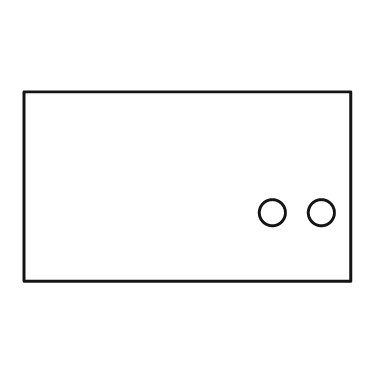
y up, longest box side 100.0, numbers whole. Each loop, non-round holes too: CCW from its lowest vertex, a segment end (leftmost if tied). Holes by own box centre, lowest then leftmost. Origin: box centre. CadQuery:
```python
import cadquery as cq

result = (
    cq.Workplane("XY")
    .moveTo(-50.0, -29.0)
    .lineTo(50.0, -29.0)
    .lineTo(50.0, 29.0)
    .lineTo(-50.0, 29.0)
    .close()
    .moveTo(26.0, -8.0)
    .circle(4.0)
    .moveTo(41.0, -8.0)
    .circle(4.0)
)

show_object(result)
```